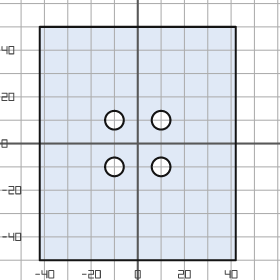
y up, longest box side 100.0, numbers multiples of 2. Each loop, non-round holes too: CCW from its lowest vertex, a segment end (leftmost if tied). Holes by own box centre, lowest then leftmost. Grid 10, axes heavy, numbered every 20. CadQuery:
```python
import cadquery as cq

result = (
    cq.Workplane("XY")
    .moveTo(-42.0, -50.0)
    .lineTo(42.0, -50.0)
    .lineTo(42.0, 50.0)
    .lineTo(-42.0, 50.0)
    .close()
    .moveTo(-10.0, -10.0)
    .circle(4.0)
    .moveTo(10.0, -10.0)
    .circle(4.0)
    .moveTo(-10.0, 10.0)
    .circle(4.0)
    .moveTo(10.0, 10.0)
    .circle(4.0)
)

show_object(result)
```